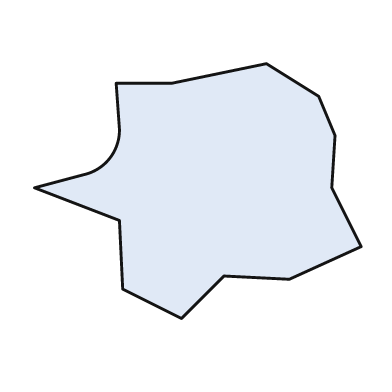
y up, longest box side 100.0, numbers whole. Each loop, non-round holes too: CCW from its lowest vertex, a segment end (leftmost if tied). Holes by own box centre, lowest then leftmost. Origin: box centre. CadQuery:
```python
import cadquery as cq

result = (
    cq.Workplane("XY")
    .moveTo(-5.0, -39.0)
    .lineTo(8.0, -26.0)
    .lineTo(28.0, -27.0)
    .lineTo(50.0, -17.0)
    .lineTo(41.0, 1.0)
    .lineTo(42.0, 17.0)
    .lineTo(37.0, 29.0)
    .lineTo(21.0, 39.0)
    .lineTo(-8.0, 33.0)
    .lineTo(-25.0, 33.0)
    .lineTo(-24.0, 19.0)
    .threePointArc((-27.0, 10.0), (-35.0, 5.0))
    .lineTo(-50.0, 1.0)
    .lineTo(-24.0, -9.0)
    .lineTo(-23.0, -30.0)
    .close()
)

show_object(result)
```